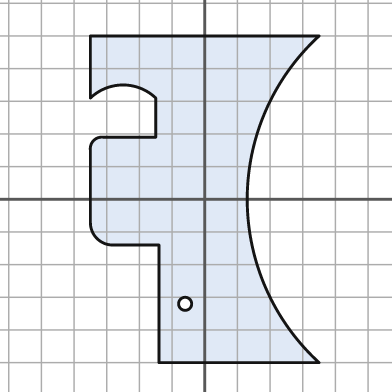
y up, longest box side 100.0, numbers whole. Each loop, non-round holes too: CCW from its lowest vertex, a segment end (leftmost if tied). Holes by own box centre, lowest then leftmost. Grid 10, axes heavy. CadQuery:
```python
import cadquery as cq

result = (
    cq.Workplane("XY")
    .moveTo(-14.0, -50.0)
    .lineTo(35.0, -50.0)
    .threePointArc((13.0, 0.0), (35.0, 50.0))
    .lineTo(-35.0, 50.0)
    .lineTo(-35.0, 31.0)
    .threePointArc((-25.0, 35.0), (-15.0, 31.0))
    .lineTo(-15.0, 19.0)
    .lineTo(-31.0, 19.0)
    .threePointArc((-34.0, 18.0), (-35.0, 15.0))
    .lineTo(-35.0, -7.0)
    .threePointArc((-33.0, -12.0), (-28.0, -14.0))
    .lineTo(-14.0, -14.0)
    .close()
    .moveTo(-6.0, -32.0)
    .circle(2.0)
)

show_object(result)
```